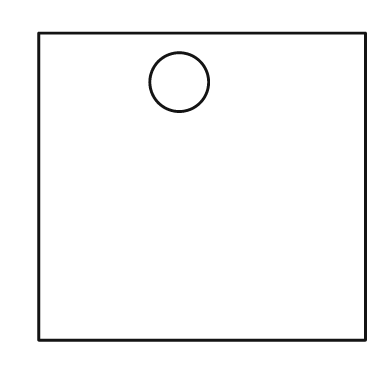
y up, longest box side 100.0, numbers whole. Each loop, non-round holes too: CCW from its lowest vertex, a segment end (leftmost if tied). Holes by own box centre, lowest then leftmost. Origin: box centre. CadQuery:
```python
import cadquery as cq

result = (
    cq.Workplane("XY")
    .moveTo(-50.0, -47.0)
    .lineTo(50.0, -47.0)
    .lineTo(50.0, 47.0)
    .lineTo(-50.0, 47.0)
    .close()
    .moveTo(-7.0, 32.0)
    .circle(9.0)
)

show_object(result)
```